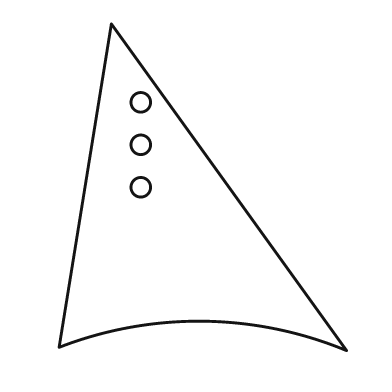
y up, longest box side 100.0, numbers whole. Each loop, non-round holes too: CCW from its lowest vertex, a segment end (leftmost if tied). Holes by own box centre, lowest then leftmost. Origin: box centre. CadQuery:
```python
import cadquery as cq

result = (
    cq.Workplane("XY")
    .moveTo(44.0, -50.0)
    .lineTo(-28.0, 50.0)
    .lineTo(-44.0, -49.0)
    .threePointArc((0.0, -41.0), (44.0, -50.0))
    .close()
    .moveTo(-19.0, 0.0)
    .circle(3.0)
    .moveTo(-19.0, 13.0)
    .circle(3.0)
    .moveTo(-19.0, 26.0)
    .circle(3.0)
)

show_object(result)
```